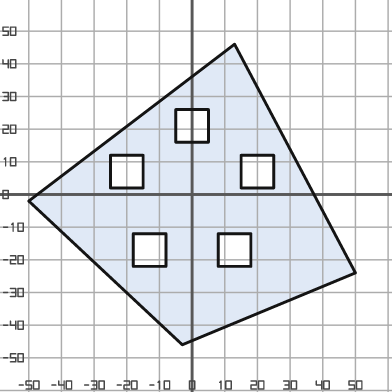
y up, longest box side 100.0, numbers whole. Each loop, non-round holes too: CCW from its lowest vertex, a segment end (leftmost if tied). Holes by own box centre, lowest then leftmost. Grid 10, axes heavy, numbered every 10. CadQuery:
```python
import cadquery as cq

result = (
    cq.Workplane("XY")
    .moveTo(-3.0, -46.0)
    .lineTo(50.0, -24.0)
    .lineTo(13.0, 46.0)
    .lineTo(-50.0, -2.0)
    .close()
    .moveTo(-18.0, -22.0)
    .lineTo(-8.0, -22.0)
    .lineTo(-8.0, -12.0)
    .lineTo(-18.0, -12.0)
    .close()
    .moveTo(8.0, -22.0)
    .lineTo(18.0, -22.0)
    .lineTo(18.0, -12.0)
    .lineTo(8.0, -12.0)
    .close()
    .moveTo(-25.0, 2.0)
    .lineTo(-15.0, 2.0)
    .lineTo(-15.0, 12.0)
    .lineTo(-25.0, 12.0)
    .close()
    .moveTo(15.0, 2.0)
    .lineTo(25.0, 2.0)
    .lineTo(25.0, 12.0)
    .lineTo(15.0, 12.0)
    .close()
    .moveTo(-5.0, 16.0)
    .lineTo(5.0, 16.0)
    .lineTo(5.0, 26.0)
    .lineTo(-5.0, 26.0)
    .close()
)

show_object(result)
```